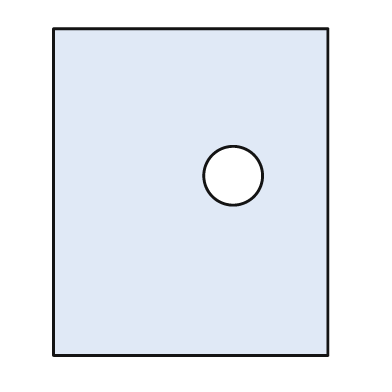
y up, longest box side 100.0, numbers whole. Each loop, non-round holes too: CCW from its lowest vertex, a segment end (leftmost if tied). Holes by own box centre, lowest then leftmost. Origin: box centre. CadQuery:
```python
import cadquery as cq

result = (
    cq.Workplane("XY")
    .moveTo(-42.0, -50.0)
    .lineTo(42.0, -50.0)
    .lineTo(42.0, 50.0)
    .lineTo(-42.0, 50.0)
    .close()
    .moveTo(13.0, 5.0)
    .circle(9.0)
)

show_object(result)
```